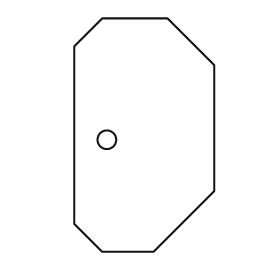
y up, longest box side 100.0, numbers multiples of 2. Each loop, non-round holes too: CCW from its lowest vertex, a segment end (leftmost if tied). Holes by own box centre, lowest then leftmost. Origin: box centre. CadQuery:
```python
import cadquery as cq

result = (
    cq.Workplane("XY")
    .moveTo(-18.0, -50.0)
    .lineTo(4.0, -50.0)
    .lineTo(30.0, -24.0)
    .lineTo(30.0, 30.0)
    .lineTo(10.0, 50.0)
    .lineTo(-18.0, 50.0)
    .lineTo(-30.0, 38.0)
    .lineTo(-30.0, -38.0)
    .close()
    .moveTo(-16.0, -2.0)
    .circle(4.0)
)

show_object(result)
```